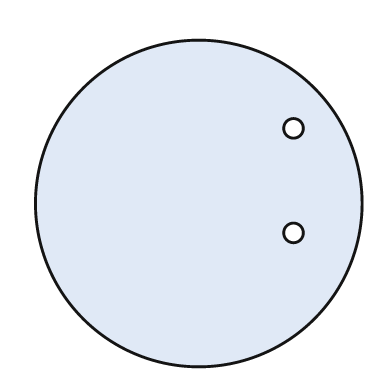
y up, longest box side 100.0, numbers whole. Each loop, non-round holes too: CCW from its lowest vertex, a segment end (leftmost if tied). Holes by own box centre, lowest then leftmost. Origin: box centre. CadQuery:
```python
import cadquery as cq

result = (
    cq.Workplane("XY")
    .moveTo(0.0, 0.0)
    .circle(50.0)
    .moveTo(29.0, -9.0)
    .circle(3.0)
    .moveTo(29.0, 23.0)
    .circle(3.0)
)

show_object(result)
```